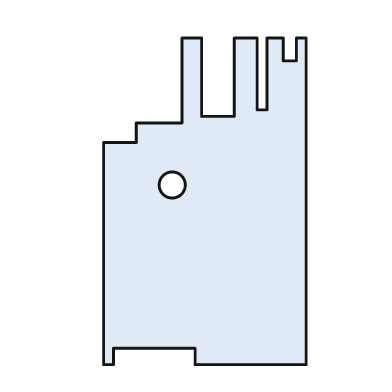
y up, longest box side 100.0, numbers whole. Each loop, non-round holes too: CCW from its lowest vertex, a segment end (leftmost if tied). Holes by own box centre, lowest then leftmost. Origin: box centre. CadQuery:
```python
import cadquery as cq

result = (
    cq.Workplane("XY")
    .moveTo(-31.0, -50.0)
    .lineTo(-28.0, -50.0)
    .lineTo(-28.0, -45.0)
    .lineTo(-3.0, -45.0)
    .lineTo(-3.0, -50.0)
    .lineTo(31.0, -50.0)
    .lineTo(31.0, 50.0)
    .lineTo(28.0, 50.0)
    .lineTo(28.0, 43.0)
    .lineTo(24.0, 43.0)
    .lineTo(24.0, 50.0)
    .lineTo(19.0, 50.0)
    .lineTo(19.0, 28.0)
    .lineTo(16.0, 28.0)
    .lineTo(16.0, 50.0)
    .lineTo(9.0, 50.0)
    .lineTo(9.0, 26.0)
    .lineTo(-1.0, 26.0)
    .lineTo(-1.0, 50.0)
    .lineTo(-7.0, 50.0)
    .lineTo(-7.0, 24.0)
    .lineTo(-21.0, 24.0)
    .lineTo(-21.0, 18.0)
    .lineTo(-31.0, 18.0)
    .close()
    .moveTo(-10.0, 5.0)
    .circle(4.0)
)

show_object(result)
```